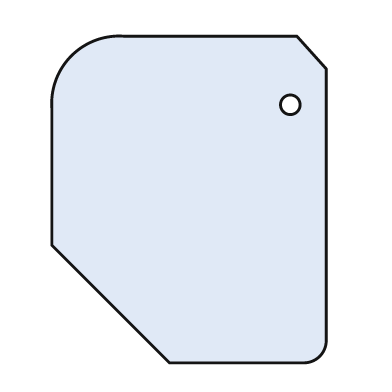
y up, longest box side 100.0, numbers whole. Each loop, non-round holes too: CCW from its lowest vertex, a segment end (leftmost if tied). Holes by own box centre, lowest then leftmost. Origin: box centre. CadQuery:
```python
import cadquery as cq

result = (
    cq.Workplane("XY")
    .moveTo(-6.0, -50.0)
    .lineTo(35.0, -50.0)
    .threePointArc((40.0, -48.0), (42.0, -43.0))
    .lineTo(42.0, 40.0)
    .lineTo(33.0, 50.0)
    .lineTo(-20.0, 50.0)
    .threePointArc((-36.0, 44.0), (-42.0, 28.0))
    .lineTo(-42.0, -14.0)
    .close()
    .moveTo(31.0, 29.0)
    .circle(3.0)
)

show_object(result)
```